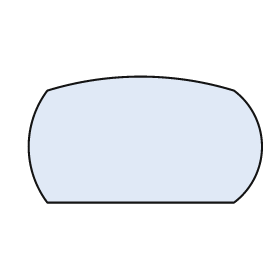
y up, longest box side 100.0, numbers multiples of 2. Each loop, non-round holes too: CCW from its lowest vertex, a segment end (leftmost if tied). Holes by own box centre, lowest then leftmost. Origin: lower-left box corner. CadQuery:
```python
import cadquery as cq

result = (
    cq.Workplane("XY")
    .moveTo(8.0, 0.0)
    .lineTo(88.0, 0.0)
    .threePointArc((100.0, 24.0), (88.0, 48.0))
    .threePointArc((48.0, 54.0), (8.0, 48.0))
    .threePointArc((0.0, 24.0), (8.0, 0.0))
    .close()
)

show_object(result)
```